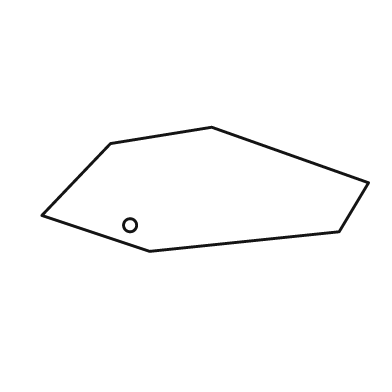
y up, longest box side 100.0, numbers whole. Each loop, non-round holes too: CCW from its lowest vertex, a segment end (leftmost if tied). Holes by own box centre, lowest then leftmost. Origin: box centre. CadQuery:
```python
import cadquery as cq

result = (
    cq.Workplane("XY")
    .moveTo(-17.0, -19.0)
    .lineTo(41.0, -13.0)
    .lineTo(50.0, 2.0)
    .lineTo(2.0, 19.0)
    .lineTo(-29.0, 14.0)
    .lineTo(-50.0, -8.0)
    .close()
    .moveTo(-23.0, -11.0)
    .circle(2.0)
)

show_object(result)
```